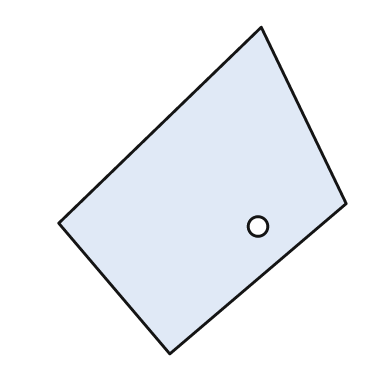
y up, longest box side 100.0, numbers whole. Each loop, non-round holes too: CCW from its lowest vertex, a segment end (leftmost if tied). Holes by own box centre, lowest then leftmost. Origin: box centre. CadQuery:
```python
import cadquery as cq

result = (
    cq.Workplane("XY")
    .moveTo(-10.0, -50.0)
    .lineTo(44.0, -4.0)
    .lineTo(18.0, 50.0)
    .lineTo(-44.0, -10.0)
    .close()
    .moveTo(17.0, -11.0)
    .circle(3.0)
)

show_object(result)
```